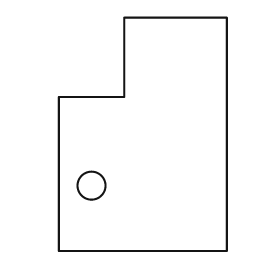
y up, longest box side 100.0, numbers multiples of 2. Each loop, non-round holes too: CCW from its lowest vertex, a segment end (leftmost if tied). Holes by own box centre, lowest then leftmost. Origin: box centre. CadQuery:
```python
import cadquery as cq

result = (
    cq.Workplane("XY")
    .moveTo(-36.0, -50.0)
    .lineTo(36.0, -50.0)
    .lineTo(36.0, 50.0)
    .lineTo(-8.0, 50.0)
    .lineTo(-8.0, 16.0)
    .lineTo(-36.0, 16.0)
    .close()
    .moveTo(-22.0, -22.0)
    .circle(6.0)
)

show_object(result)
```